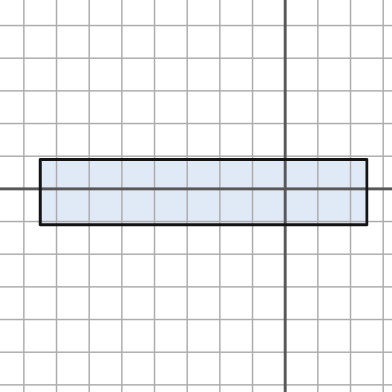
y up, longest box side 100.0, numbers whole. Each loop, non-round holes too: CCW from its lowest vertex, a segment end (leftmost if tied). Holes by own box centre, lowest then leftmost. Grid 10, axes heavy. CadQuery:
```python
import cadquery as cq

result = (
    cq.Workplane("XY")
    .moveTo(-75.0, -11.0)
    .lineTo(25.0, -11.0)
    .lineTo(25.0, 9.0)
    .lineTo(-75.0, 9.0)
    .close()
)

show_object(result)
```